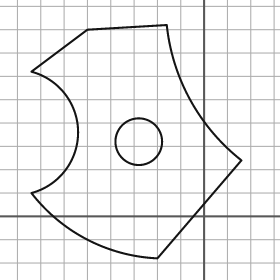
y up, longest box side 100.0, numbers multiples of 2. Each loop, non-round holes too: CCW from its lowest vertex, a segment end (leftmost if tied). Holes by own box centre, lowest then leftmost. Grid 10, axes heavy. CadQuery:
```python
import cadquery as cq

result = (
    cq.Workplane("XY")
    .moveTo(-20.0, -18.0)
    .lineTo(16.0, 24.0)
    .threePointArc((-6.0, 50.0), (-16.0, 82.0))
    .lineTo(-50.0, 80.0)
    .lineTo(-74.0, 62.0)
    .threePointArc((-54.0, 36.0), (-74.0, 10.0))
    .threePointArc((-50.0, -10.0), (-20.0, -18.0))
    .close()
    .moveTo(-28.0, 32.0)
    .circle(10.0)
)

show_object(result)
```